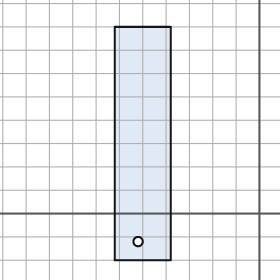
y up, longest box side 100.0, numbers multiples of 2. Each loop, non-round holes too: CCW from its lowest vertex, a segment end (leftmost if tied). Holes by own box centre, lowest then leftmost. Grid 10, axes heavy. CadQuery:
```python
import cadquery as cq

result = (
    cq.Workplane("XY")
    .moveTo(-62.0, -20.0)
    .lineTo(-38.0, -20.0)
    .lineTo(-38.0, 80.0)
    .lineTo(-62.0, 80.0)
    .close()
    .moveTo(-52.0, -12.0)
    .circle(2.0)
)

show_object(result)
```